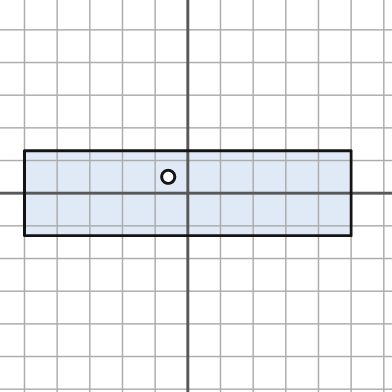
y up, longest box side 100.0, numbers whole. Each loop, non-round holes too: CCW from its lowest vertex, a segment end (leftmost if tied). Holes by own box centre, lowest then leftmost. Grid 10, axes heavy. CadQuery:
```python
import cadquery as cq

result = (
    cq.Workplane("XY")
    .moveTo(-50.0, -13.0)
    .lineTo(50.0, -13.0)
    .lineTo(50.0, 13.0)
    .lineTo(-50.0, 13.0)
    .close()
    .moveTo(-6.0, 5.0)
    .circle(2.0)
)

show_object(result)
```